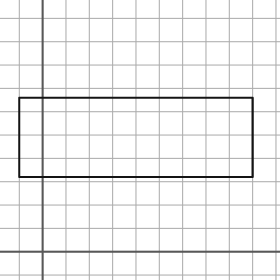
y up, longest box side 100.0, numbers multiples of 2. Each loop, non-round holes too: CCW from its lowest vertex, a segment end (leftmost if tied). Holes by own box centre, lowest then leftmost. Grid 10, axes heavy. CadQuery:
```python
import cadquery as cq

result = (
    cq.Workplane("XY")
    .moveTo(-10.0, 32.0)
    .lineTo(90.0, 32.0)
    .lineTo(90.0, 66.0)
    .lineTo(-10.0, 66.0)
    .close()
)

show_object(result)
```